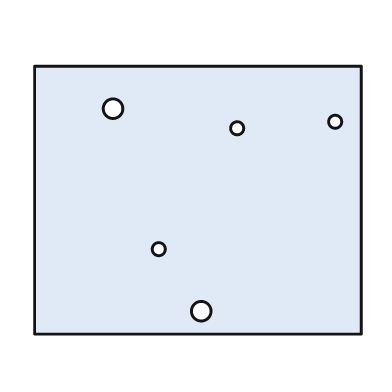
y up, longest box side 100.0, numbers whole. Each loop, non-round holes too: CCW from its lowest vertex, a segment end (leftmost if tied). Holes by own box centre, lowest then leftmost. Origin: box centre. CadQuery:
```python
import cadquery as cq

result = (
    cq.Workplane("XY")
    .moveTo(-50.0, -41.0)
    .lineTo(50.0, -41.0)
    .lineTo(50.0, 41.0)
    .lineTo(-50.0, 41.0)
    .close()
    .moveTo(1.0, -34.0)
    .circle(3.0)
    .moveTo(-12.0, -15.0)
    .circle(2.0)
    .moveTo(12.0, 22.0)
    .circle(2.0)
    .moveTo(42.0, 24.0)
    .circle(2.0)
    .moveTo(-26.0, 28.0)
    .circle(3.0)
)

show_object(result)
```